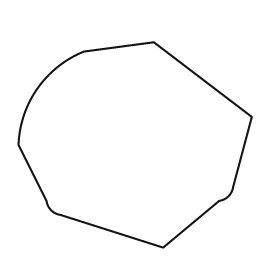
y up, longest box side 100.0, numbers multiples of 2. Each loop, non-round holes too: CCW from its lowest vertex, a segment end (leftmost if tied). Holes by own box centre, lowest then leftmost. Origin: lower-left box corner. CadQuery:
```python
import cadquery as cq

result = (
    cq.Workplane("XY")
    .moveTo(62.0, 0.0)
    .lineTo(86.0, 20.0)
    .threePointArc((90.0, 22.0), (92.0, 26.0))
    .lineTo(100.0, 56.0)
    .lineTo(58.0, 88.0)
    .lineTo(28.0, 84.0)
    .threePointArc((8.0, 68.0), (0.0, 44.0))
    .lineTo(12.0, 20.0)
    .threePointArc((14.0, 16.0), (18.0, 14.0))
    .close()
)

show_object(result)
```